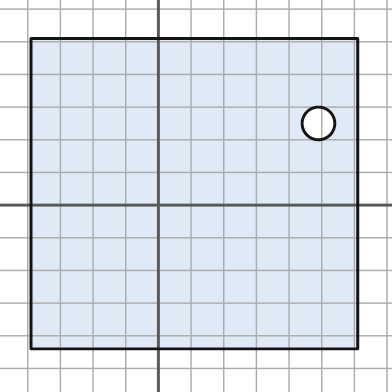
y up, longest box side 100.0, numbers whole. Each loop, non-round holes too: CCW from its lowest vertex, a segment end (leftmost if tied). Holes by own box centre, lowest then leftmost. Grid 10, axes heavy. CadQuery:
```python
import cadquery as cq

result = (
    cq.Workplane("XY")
    .moveTo(-39.0, -44.0)
    .lineTo(61.0, -44.0)
    .lineTo(61.0, 51.0)
    .lineTo(-39.0, 51.0)
    .close()
    .moveTo(49.0, 25.0)
    .circle(5.0)
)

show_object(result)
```